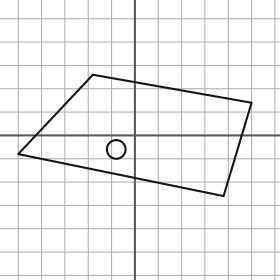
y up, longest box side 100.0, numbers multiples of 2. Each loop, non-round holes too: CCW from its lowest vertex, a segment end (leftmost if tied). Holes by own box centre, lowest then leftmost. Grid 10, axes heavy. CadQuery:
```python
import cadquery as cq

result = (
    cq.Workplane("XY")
    .moveTo(38.0, -26.0)
    .lineTo(50.0, 14.0)
    .lineTo(-18.0, 26.0)
    .lineTo(-50.0, -8.0)
    .close()
    .moveTo(-8.0, -6.0)
    .circle(4.0)
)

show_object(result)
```